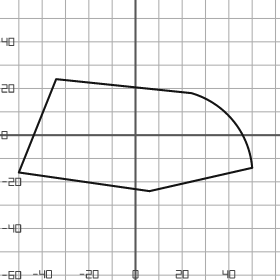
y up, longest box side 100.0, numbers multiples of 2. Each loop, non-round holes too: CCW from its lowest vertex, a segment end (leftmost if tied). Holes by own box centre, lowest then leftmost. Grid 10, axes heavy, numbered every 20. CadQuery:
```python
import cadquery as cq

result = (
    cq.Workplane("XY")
    .moveTo(6.0, -24.0)
    .lineTo(50.0, -14.0)
    .threePointArc((42.0, 6.0), (24.0, 18.0))
    .lineTo(-34.0, 24.0)
    .lineTo(-50.0, -16.0)
    .close()
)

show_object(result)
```